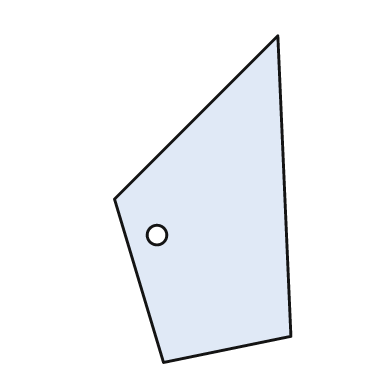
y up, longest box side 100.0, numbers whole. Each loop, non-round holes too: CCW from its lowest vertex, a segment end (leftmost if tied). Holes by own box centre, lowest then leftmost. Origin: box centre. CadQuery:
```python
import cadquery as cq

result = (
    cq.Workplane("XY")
    .moveTo(-12.0, -50.0)
    .lineTo(27.0, -42.0)
    .lineTo(23.0, 50.0)
    .lineTo(-27.0, 0.0)
    .close()
    .moveTo(-14.0, -11.0)
    .circle(3.0)
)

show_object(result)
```